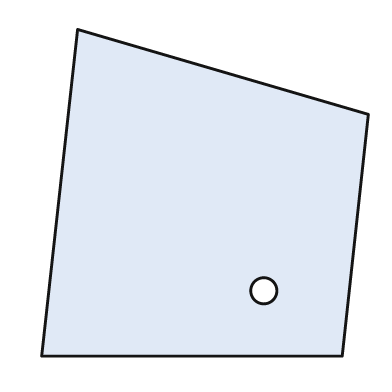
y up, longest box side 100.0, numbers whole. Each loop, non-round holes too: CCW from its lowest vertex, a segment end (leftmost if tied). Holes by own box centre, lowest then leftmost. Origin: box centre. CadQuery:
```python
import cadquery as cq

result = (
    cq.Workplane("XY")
    .moveTo(-50.0, -50.0)
    .lineTo(42.0, -50.0)
    .lineTo(50.0, 24.0)
    .lineTo(-39.0, 50.0)
    .close()
    .moveTo(18.0, -30.0)
    .circle(4.0)
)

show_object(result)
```